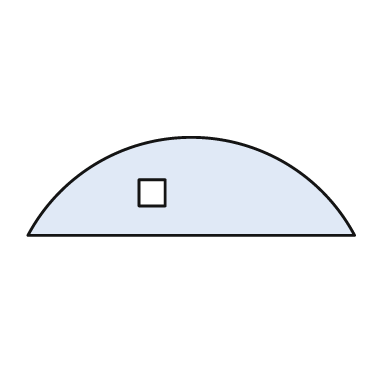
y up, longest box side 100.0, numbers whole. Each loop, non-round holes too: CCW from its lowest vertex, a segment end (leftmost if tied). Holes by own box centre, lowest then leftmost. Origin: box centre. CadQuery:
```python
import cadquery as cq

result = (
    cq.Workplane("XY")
    .moveTo(-50.0, -15.0)
    .lineTo(50.0, -15.0)
    .threePointArc((0.0, 15.0), (-50.0, -15.0))
    .close()
    .moveTo(-16.0, -6.0)
    .lineTo(-8.0, -6.0)
    .lineTo(-8.0, 2.0)
    .lineTo(-16.0, 2.0)
    .close()
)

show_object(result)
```